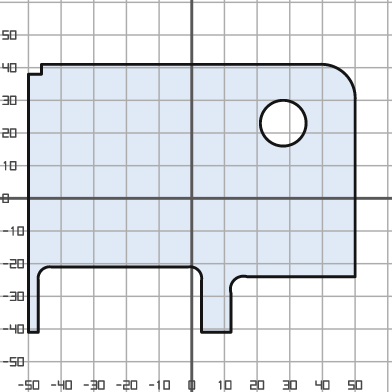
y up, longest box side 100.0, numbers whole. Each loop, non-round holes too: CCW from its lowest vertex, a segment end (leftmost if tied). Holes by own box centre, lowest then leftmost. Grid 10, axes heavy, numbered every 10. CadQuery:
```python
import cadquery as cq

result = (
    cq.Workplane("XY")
    .moveTo(-50.0, -41.0)
    .lineTo(-47.0, -41.0)
    .lineTo(-47.0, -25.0)
    .threePointArc((-46.0, -22.0), (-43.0, -21.0))
    .lineTo(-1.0, -21.0)
    .threePointArc((2.0, -22.0), (3.0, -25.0))
    .lineTo(3.0, -41.0)
    .lineTo(12.0, -41.0)
    .lineTo(12.0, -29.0)
    .threePointArc((13.0, -25.0), (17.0, -24.0))
    .lineTo(50.0, -24.0)
    .lineTo(50.0, 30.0)
    .threePointArc((47.0, 38.0), (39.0, 41.0))
    .lineTo(-46.0, 41.0)
    .lineTo(-46.0, 38.0)
    .lineTo(-50.0, 38.0)
    .close()
    .moveTo(28.0, 23.0)
    .circle(7.0)
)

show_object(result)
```